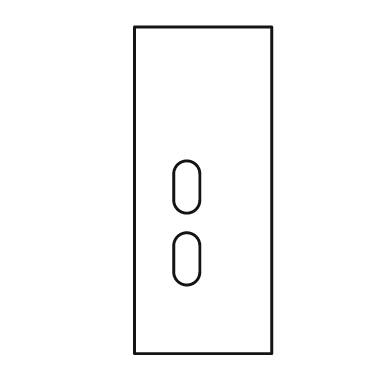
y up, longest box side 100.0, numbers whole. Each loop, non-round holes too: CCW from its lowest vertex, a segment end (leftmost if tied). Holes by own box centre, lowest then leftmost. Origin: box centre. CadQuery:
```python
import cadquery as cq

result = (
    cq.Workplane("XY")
    .moveTo(-21.0, -50.0)
    .lineTo(21.0, -50.0)
    .lineTo(21.0, 50.0)
    .lineTo(-21.0, 50.0)
    .close()
    .moveTo(-9.0, -25.0)
    .threePointArc((-5.0, -29.0), (-1.0, -25.0))
    .lineTo(-1.0, -17.0)
    .threePointArc((-5.0, -13.0), (-9.0, -17.0))
    .close()
    .moveTo(-9.0, -3.0)
    .threePointArc((-5.0, -7.0), (-1.0, -3.0))
    .lineTo(-1.0, 5.0)
    .threePointArc((-5.0, 9.0), (-9.0, 5.0))
    .close()
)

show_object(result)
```